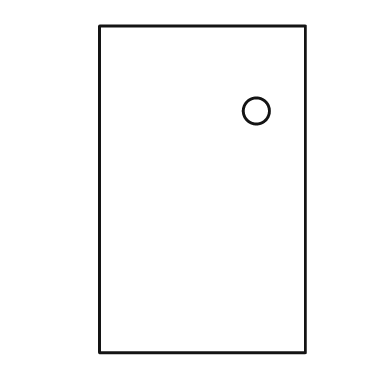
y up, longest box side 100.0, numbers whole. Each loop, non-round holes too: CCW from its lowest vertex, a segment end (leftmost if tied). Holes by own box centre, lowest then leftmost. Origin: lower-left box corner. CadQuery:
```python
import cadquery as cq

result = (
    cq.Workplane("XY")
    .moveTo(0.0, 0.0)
    .lineTo(63.0, 0.0)
    .lineTo(63.0, 100.0)
    .lineTo(0.0, 100.0)
    .close()
    .moveTo(48.0, 74.0)
    .circle(4.0)
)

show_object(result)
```